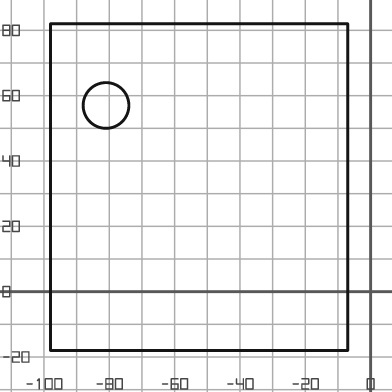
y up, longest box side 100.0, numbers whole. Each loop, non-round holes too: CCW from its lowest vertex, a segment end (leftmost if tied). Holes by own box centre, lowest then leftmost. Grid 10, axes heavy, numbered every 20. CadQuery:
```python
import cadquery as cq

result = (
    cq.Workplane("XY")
    .moveTo(-98.0, -18.0)
    .lineTo(-7.0, -18.0)
    .lineTo(-7.0, 82.0)
    .lineTo(-98.0, 82.0)
    .close()
    .moveTo(-81.0, 57.0)
    .circle(7.0)
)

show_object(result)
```